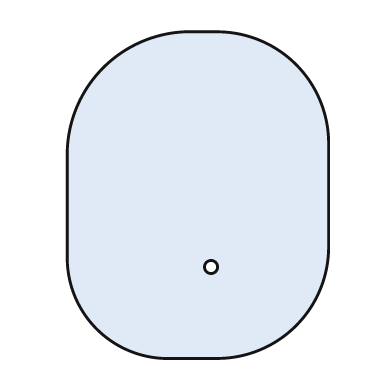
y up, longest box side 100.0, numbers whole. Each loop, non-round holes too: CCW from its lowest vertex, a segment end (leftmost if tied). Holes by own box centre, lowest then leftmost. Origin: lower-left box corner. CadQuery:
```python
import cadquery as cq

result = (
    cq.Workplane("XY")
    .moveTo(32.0, 0.0)
    .lineTo(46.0, 0.0)
    .threePointArc((70.0, 10.0), (80.0, 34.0))
    .lineTo(80.0, 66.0)
    .threePointArc((70.0, 90.0), (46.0, 100.0))
    .lineTo(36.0, 100.0)
    .threePointArc((11.0, 89.0), (0.0, 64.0))
    .lineTo(0.0, 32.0)
    .threePointArc((9.0, 9.0), (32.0, 0.0))
    .close()
    .moveTo(44.0, 28.0)
    .circle(2.0)
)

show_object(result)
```